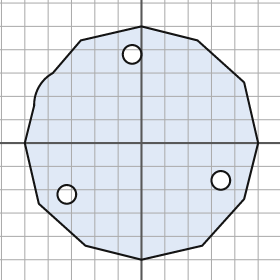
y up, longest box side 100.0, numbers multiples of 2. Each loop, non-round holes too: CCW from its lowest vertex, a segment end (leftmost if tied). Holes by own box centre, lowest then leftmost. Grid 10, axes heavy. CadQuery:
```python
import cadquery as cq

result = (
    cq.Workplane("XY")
    .moveTo(0.0, -50.0)
    .lineTo(26.0, -44.0)
    .lineTo(44.0, -24.0)
    .lineTo(50.0, 0.0)
    .lineTo(44.0, 26.0)
    .lineTo(24.0, 44.0)
    .lineTo(0.0, 50.0)
    .lineTo(-26.0, 44.0)
    .lineTo(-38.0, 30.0)
    .threePointArc((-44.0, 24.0), (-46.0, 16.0))
    .lineTo(-50.0, 0.0)
    .lineTo(-44.0, -26.0)
    .lineTo(-24.0, -44.0)
    .close()
    .moveTo(-32.0, -22.0)
    .circle(4.0)
    .moveTo(34.0, -16.0)
    .circle(4.0)
    .moveTo(-4.0, 38.0)
    .circle(4.0)
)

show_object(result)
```